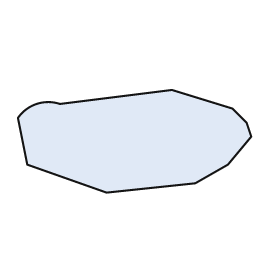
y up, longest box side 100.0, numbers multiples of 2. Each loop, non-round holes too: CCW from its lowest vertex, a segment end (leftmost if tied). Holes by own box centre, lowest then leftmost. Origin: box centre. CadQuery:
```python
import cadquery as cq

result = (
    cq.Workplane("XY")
    .moveTo(-12.0, -22.0)
    .lineTo(26.0, -18.0)
    .lineTo(40.0, -10.0)
    .lineTo(50.0, 2.0)
    .lineTo(48.0, 8.0)
    .lineTo(42.0, 14.0)
    .lineTo(16.0, 22.0)
    .lineTo(-32.0, 16.0)
    .threePointArc((-42.0, 16.0), (-50.0, 10.0))
    .lineTo(-46.0, -10.0)
    .close()
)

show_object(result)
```